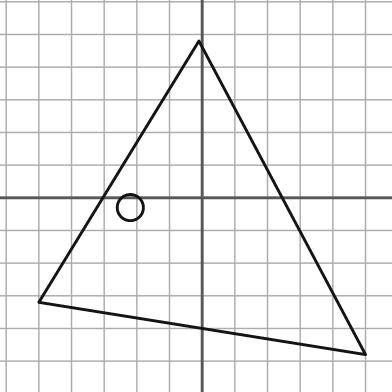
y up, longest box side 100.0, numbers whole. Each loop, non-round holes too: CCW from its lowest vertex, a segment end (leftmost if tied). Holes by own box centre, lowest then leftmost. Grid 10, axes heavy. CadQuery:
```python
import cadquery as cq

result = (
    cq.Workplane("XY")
    .moveTo(50.0, -48.0)
    .lineTo(-1.0, 48.0)
    .lineTo(-50.0, -32.0)
    .close()
    .moveTo(-22.0, -3.0)
    .circle(4.0)
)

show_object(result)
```